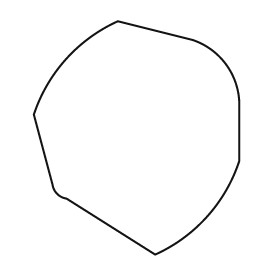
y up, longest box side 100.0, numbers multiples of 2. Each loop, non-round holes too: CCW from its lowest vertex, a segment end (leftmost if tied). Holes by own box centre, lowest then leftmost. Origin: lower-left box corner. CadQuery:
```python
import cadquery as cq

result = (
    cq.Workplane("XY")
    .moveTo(52.0, 0.0)
    .threePointArc((74.0, 16.0), (88.0, 40.0))
    .lineTo(88.0, 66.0)
    .threePointArc((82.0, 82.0), (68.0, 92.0))
    .lineTo(36.0, 100.0)
    .threePointArc((14.0, 84.0), (0.0, 60.0))
    .lineTo(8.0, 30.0)
    .threePointArc((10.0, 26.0), (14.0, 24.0))
    .close()
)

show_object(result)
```